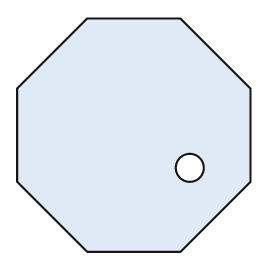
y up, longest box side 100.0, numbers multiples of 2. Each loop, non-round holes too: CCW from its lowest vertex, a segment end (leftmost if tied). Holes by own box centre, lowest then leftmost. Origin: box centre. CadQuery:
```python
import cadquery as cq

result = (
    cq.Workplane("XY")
    .moveTo(-20.0, -50.0)
    .lineTo(20.0, -50.0)
    .lineTo(50.0, -20.0)
    .lineTo(50.0, 20.0)
    .lineTo(20.0, 50.0)
    .lineTo(-20.0, 50.0)
    .lineTo(-50.0, 20.0)
    .lineTo(-50.0, -20.0)
    .close()
    .moveTo(24.0, -14.0)
    .circle(6.0)
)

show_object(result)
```